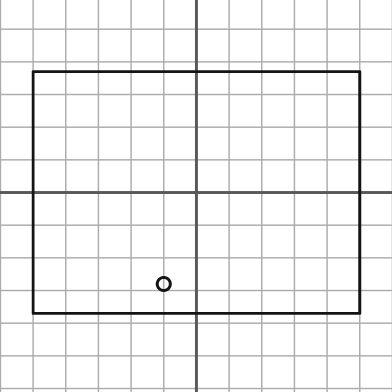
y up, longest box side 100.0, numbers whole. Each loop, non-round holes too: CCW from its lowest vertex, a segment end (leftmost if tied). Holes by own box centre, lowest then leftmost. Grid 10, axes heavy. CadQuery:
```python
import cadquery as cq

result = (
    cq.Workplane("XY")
    .moveTo(-50.0, -37.0)
    .lineTo(50.0, -37.0)
    .lineTo(50.0, 37.0)
    .lineTo(-50.0, 37.0)
    .close()
    .moveTo(-10.0, -28.0)
    .circle(2.0)
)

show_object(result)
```